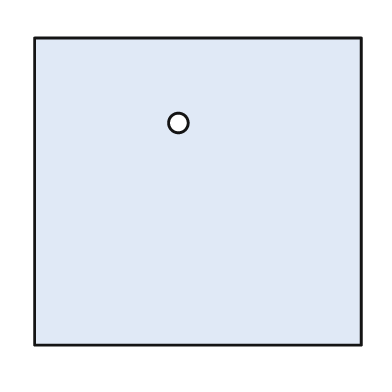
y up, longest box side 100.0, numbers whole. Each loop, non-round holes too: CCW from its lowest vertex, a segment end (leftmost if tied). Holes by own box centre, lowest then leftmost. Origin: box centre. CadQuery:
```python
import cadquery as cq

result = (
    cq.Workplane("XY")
    .moveTo(-50.0, -47.0)
    .lineTo(50.0, -47.0)
    .lineTo(50.0, 47.0)
    .lineTo(-50.0, 47.0)
    .close()
    .moveTo(-6.0, 21.0)
    .circle(3.0)
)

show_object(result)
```